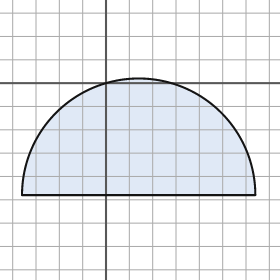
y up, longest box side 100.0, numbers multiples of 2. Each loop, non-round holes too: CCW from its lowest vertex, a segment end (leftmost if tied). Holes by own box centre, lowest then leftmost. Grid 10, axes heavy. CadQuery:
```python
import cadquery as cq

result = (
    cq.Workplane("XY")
    .moveTo(-36.0, -48.0)
    .lineTo(64.0, -48.0)
    .threePointArc((14.0, 2.0), (-36.0, -48.0))
    .close()
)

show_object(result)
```